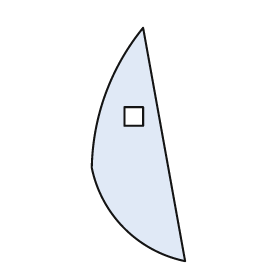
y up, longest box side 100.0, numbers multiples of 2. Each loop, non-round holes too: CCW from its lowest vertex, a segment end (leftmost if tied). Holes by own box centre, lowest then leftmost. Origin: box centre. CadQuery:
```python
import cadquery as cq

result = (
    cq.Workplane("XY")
    .moveTo(20.0, -50.0)
    .lineTo(2.0, 50.0)
    .threePointArc((-14.0, 22.0), (-20.0, -10.0))
    .threePointArc((-6.0, -36.0), (20.0, -50.0))
    .close()
    .moveTo(-6.0, 8.0)
    .lineTo(2.0, 8.0)
    .lineTo(2.0, 16.0)
    .lineTo(-6.0, 16.0)
    .close()
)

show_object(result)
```